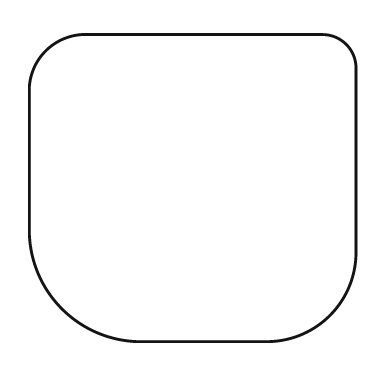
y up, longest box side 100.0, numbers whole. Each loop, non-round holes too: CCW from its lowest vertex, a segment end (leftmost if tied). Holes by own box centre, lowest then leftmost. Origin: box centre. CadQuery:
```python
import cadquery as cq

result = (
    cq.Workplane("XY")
    .moveTo(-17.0, -47.0)
    .lineTo(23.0, -47.0)
    .threePointArc((42.0, -39.0), (50.0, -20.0))
    .lineTo(50.0, 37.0)
    .threePointArc((47.0, 44.0), (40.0, 47.0))
    .lineTo(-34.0, 47.0)
    .threePointArc((-45.0, 42.0), (-50.0, 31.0))
    .lineTo(-50.0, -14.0)
    .threePointArc((-40.0, -37.0), (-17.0, -47.0))
    .close()
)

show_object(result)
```